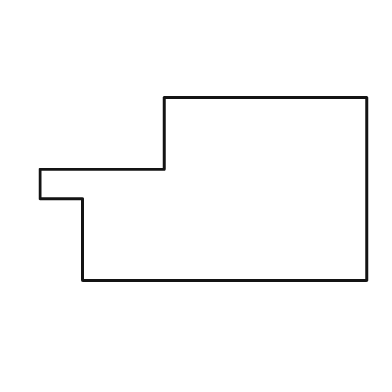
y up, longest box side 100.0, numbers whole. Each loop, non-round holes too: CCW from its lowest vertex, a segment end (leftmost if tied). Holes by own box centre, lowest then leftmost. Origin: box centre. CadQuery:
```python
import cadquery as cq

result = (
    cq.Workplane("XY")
    .moveTo(-37.0, -28.0)
    .lineTo(50.0, -28.0)
    .lineTo(50.0, 28.0)
    .lineTo(-12.0, 28.0)
    .lineTo(-12.0, 6.0)
    .lineTo(-50.0, 6.0)
    .lineTo(-50.0, -3.0)
    .lineTo(-37.0, -3.0)
    .close()
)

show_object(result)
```